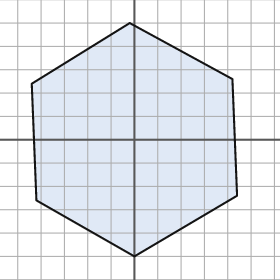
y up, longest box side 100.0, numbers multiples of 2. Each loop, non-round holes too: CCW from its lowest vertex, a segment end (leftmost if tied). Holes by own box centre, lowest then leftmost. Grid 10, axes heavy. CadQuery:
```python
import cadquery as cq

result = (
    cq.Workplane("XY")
    .moveTo(0.0, -50.0)
    .lineTo(44.0, -24.0)
    .lineTo(42.0, 26.0)
    .lineTo(-2.0, 50.0)
    .lineTo(-44.0, 24.0)
    .lineTo(-42.0, -26.0)
    .close()
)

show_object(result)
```